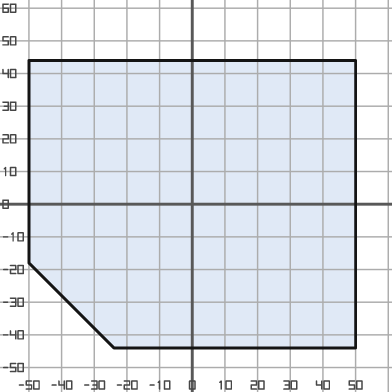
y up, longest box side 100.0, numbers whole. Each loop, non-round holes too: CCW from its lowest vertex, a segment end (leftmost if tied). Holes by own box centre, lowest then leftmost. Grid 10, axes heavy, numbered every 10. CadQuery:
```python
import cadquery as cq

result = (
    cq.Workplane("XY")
    .moveTo(-24.0, -44.0)
    .lineTo(50.0, -44.0)
    .lineTo(50.0, 44.0)
    .lineTo(-50.0, 44.0)
    .lineTo(-50.0, -18.0)
    .close()
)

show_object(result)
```